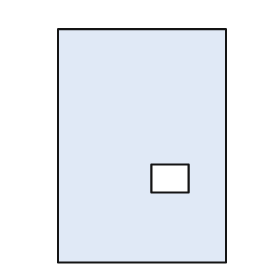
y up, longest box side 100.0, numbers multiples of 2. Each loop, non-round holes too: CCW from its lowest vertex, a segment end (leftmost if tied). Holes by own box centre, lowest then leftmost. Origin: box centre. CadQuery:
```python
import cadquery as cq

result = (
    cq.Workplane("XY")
    .moveTo(-36.0, -50.0)
    .lineTo(36.0, -50.0)
    .lineTo(36.0, 50.0)
    .lineTo(-36.0, 50.0)
    .close()
    .moveTo(4.0, -20.0)
    .lineTo(20.0, -20.0)
    .lineTo(20.0, -8.0)
    .lineTo(4.0, -8.0)
    .close()
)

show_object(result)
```